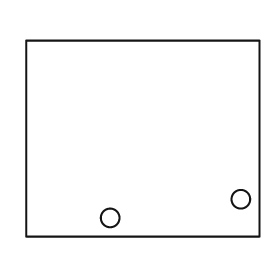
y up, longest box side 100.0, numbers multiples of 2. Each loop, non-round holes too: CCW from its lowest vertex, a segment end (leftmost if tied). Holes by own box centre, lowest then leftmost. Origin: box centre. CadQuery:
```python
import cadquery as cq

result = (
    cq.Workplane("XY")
    .moveTo(-50.0, -42.0)
    .lineTo(50.0, -42.0)
    .lineTo(50.0, 42.0)
    .lineTo(-50.0, 42.0)
    .close()
    .moveTo(-14.0, -34.0)
    .circle(4.0)
    .moveTo(42.0, -26.0)
    .circle(4.0)
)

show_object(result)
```